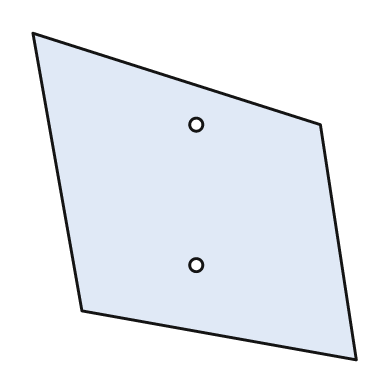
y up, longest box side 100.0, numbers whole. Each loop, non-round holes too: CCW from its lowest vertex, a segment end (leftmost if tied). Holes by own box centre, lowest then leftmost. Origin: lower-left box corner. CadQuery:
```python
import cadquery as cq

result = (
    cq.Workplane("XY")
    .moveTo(99.0, 0.0)
    .lineTo(88.0, 72.0)
    .lineTo(0.0, 100.0)
    .lineTo(15.0, 15.0)
    .close()
    .moveTo(50.0, 29.0)
    .circle(2.0)
    .moveTo(50.0, 72.0)
    .circle(2.0)
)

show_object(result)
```